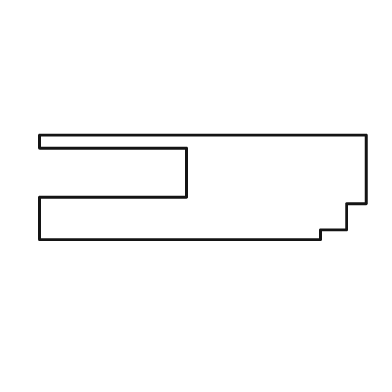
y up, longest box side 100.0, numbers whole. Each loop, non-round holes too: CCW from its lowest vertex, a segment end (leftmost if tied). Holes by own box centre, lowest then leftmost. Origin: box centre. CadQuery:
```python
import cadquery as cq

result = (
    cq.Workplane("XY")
    .moveTo(-50.0, -16.0)
    .lineTo(36.0, -16.0)
    .lineTo(36.0, -13.0)
    .lineTo(44.0, -13.0)
    .lineTo(44.0, -5.0)
    .lineTo(50.0, -5.0)
    .lineTo(50.0, 16.0)
    .lineTo(-50.0, 16.0)
    .lineTo(-50.0, 12.0)
    .lineTo(-5.0, 12.0)
    .lineTo(-5.0, -3.0)
    .lineTo(-50.0, -3.0)
    .close()
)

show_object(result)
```